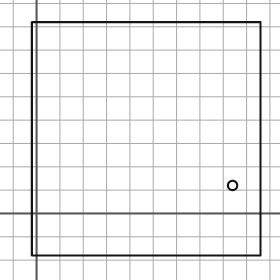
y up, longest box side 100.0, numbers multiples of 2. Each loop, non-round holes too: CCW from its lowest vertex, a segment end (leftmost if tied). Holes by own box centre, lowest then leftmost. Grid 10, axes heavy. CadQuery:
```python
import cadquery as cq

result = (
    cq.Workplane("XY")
    .moveTo(-2.0, -18.0)
    .lineTo(96.0, -18.0)
    .lineTo(96.0, 82.0)
    .lineTo(-2.0, 82.0)
    .close()
    .moveTo(84.0, 12.0)
    .circle(2.0)
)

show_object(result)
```